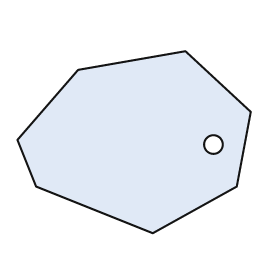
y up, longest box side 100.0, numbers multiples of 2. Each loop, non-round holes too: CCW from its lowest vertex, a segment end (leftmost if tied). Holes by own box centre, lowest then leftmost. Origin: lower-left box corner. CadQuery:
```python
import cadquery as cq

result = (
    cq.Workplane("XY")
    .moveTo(58.0, 0.0)
    .lineTo(94.0, 20.0)
    .lineTo(100.0, 52.0)
    .lineTo(72.0, 78.0)
    .lineTo(26.0, 70.0)
    .lineTo(0.0, 40.0)
    .lineTo(8.0, 20.0)
    .close()
    .moveTo(84.0, 38.0)
    .circle(4.0)
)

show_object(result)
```